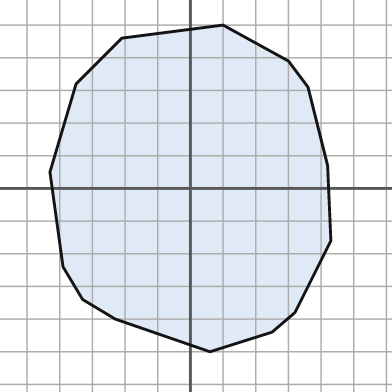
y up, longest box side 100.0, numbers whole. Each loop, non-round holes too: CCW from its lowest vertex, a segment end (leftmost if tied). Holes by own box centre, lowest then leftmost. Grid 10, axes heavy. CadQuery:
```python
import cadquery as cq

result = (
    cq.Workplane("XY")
    .moveTo(6.0, -50.0)
    .lineTo(25.0, -44.0)
    .lineTo(32.0, -38.0)
    .lineTo(43.0, -16.0)
    .lineTo(42.0, 7.0)
    .lineTo(36.0, 31.0)
    .lineTo(30.0, 39.0)
    .lineTo(10.0, 50.0)
    .lineTo(-21.0, 46.0)
    .lineTo(-35.0, 32.0)
    .lineTo(-43.0, 5.0)
    .lineTo(-39.0, -24.0)
    .lineTo(-33.0, -34.0)
    .lineTo(-23.0, -40.0)
    .close()
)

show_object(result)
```